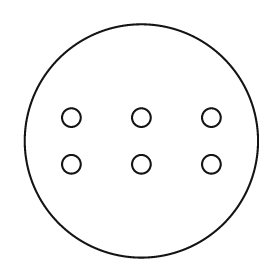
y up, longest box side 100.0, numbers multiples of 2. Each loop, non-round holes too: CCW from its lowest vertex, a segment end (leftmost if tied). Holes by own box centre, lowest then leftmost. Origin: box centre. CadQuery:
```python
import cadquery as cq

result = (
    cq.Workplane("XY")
    .moveTo(0.0, 0.0)
    .circle(50.0)
    .moveTo(-30.0, -10.0)
    .circle(4.0)
    .moveTo(0.0, -10.0)
    .circle(4.0)
    .moveTo(30.0, -10.0)
    .circle(4.0)
    .moveTo(-30.0, 10.0)
    .circle(4.0)
    .moveTo(0.0, 10.0)
    .circle(4.0)
    .moveTo(30.0, 10.0)
    .circle(4.0)
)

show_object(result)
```